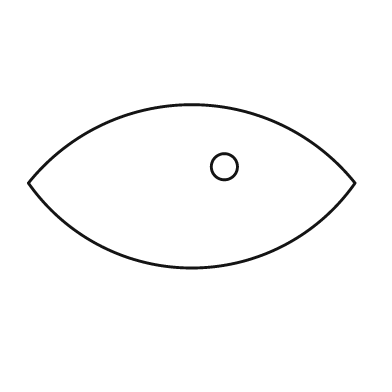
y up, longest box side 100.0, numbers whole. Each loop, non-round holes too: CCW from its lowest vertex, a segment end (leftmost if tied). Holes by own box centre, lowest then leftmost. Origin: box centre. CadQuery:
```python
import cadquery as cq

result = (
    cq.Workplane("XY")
    .moveTo(-50.0, 1.0)
    .threePointArc((0.0, -25.0), (50.0, 1.0))
    .threePointArc((0.0, 25.0), (-50.0, 1.0))
    .close()
    .moveTo(10.0, 6.0)
    .circle(4.0)
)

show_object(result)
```